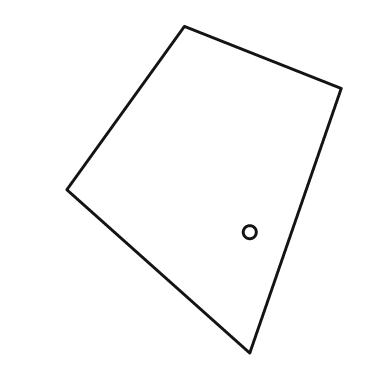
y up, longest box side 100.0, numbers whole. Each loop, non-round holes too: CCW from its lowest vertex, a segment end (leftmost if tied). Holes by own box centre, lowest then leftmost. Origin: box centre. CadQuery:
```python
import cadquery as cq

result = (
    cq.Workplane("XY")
    .moveTo(14.0, -50.0)
    .lineTo(42.0, 31.0)
    .lineTo(-6.0, 50.0)
    .lineTo(-42.0, 0.0)
    .close()
    .moveTo(14.0, -13.0)
    .circle(2.0)
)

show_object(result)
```